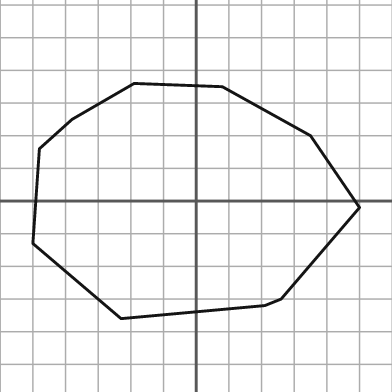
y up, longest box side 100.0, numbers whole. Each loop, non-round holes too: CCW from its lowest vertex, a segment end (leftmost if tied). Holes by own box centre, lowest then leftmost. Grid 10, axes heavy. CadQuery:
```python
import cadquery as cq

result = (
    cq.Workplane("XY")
    .moveTo(-23.0, -36.0)
    .lineTo(21.0, -32.0)
    .lineTo(26.0, -30.0)
    .lineTo(50.0, -2.0)
    .lineTo(35.0, 20.0)
    .lineTo(8.0, 35.0)
    .lineTo(-19.0, 36.0)
    .lineTo(-38.0, 25.0)
    .lineTo(-48.0, 16.0)
    .lineTo(-50.0, -13.0)
    .close()
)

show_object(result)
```